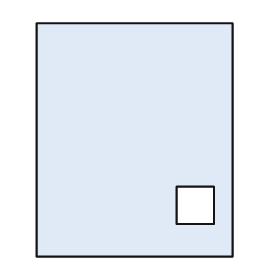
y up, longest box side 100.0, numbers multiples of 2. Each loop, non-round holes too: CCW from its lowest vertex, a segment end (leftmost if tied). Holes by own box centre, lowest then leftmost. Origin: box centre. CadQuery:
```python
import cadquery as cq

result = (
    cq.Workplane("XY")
    .moveTo(-42.0, -50.0)
    .lineTo(42.0, -50.0)
    .lineTo(42.0, 50.0)
    .lineTo(-42.0, 50.0)
    .close()
    .moveTo(18.0, -36.0)
    .lineTo(34.0, -36.0)
    .lineTo(34.0, -20.0)
    .lineTo(18.0, -20.0)
    .close()
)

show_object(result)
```